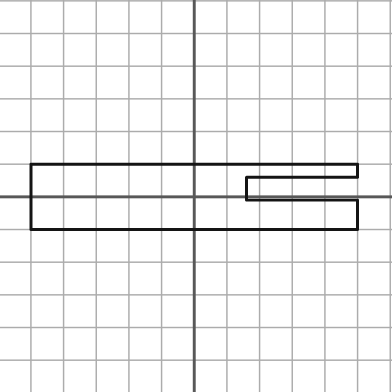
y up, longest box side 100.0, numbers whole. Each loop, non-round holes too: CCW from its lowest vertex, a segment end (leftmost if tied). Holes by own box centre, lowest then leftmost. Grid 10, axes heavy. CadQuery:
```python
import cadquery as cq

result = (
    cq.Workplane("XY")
    .moveTo(-50.0, -10.0)
    .lineTo(50.0, -10.0)
    .lineTo(50.0, -1.0)
    .lineTo(16.0, -1.0)
    .lineTo(16.0, 6.0)
    .lineTo(50.0, 6.0)
    .lineTo(50.0, 10.0)
    .lineTo(-50.0, 10.0)
    .close()
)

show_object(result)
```